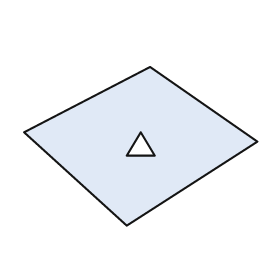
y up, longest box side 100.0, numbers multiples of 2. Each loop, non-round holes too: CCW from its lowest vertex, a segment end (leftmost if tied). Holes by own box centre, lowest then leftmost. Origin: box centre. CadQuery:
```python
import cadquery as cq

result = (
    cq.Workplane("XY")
    .moveTo(-6.0, -34.0)
    .lineTo(50.0, 2.0)
    .lineTo(4.0, 34.0)
    .lineTo(-50.0, 6.0)
    .close()
    .moveTo(-6.0, -4.0)
    .lineTo(6.0, -4.0)
    .lineTo(0.0, 6.0)
    .close()
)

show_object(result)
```